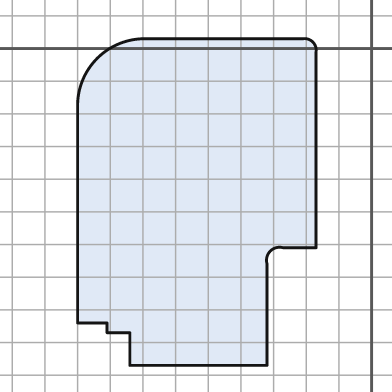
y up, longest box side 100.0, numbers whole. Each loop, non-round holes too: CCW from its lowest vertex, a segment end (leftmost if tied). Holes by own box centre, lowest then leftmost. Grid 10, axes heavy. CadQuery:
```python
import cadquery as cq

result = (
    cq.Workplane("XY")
    .moveTo(-74.0, -97.0)
    .lineTo(-32.0, -97.0)
    .lineTo(-32.0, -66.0)
    .threePointArc((-31.0, -62.0), (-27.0, -61.0))
    .lineTo(-17.0, -61.0)
    .lineTo(-17.0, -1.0)
    .threePointArc((-18.0, 2.0), (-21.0, 3.0))
    .lineTo(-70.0, 3.0)
    .threePointArc((-84.0, -3.0), (-90.0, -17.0))
    .lineTo(-90.0, -84.0)
    .lineTo(-81.0, -84.0)
    .lineTo(-81.0, -87.0)
    .lineTo(-74.0, -87.0)
    .close()
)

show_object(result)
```